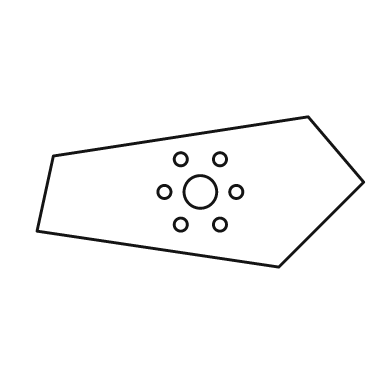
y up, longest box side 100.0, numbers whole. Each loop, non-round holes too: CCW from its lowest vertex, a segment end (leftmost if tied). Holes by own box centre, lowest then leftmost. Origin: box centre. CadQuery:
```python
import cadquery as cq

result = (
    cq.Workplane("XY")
    .moveTo(24.0, -23.0)
    .lineTo(50.0, 3.0)
    .lineTo(33.0, 23.0)
    .lineTo(-45.0, 11.0)
    .lineTo(-50.0, -12.0)
    .close()
    .moveTo(-6.0, -10.0)
    .circle(2.0)
    .moveTo(6.0, -10.0)
    .circle(2.0)
    .moveTo(-11.0, 0.0)
    .circle(2.0)
    .moveTo(0.0, 0.0)
    .circle(5.0)
    .moveTo(11.0, 0.0)
    .circle(2.0)
    .moveTo(-6.0, 10.0)
    .circle(2.0)
    .moveTo(6.0, 10.0)
    .circle(2.0)
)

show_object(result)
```